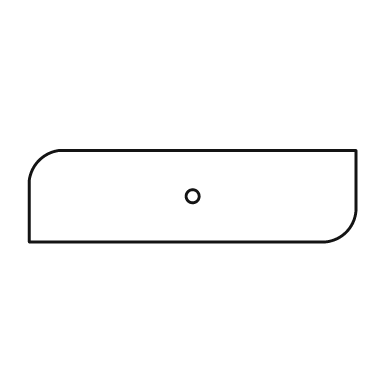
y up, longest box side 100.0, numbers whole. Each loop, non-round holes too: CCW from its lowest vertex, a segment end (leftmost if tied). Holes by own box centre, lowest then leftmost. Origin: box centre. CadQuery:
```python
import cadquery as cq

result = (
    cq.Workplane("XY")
    .moveTo(-50.0, -14.0)
    .lineTo(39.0, -14.0)
    .threePointArc((47.0, -11.0), (50.0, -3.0))
    .lineTo(50.0, 14.0)
    .lineTo(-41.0, 14.0)
    .threePointArc((-47.0, 11.0), (-50.0, 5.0))
    .close()
    .moveTo(0.0, 0.0)
    .circle(2.0)
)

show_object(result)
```